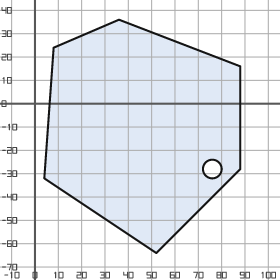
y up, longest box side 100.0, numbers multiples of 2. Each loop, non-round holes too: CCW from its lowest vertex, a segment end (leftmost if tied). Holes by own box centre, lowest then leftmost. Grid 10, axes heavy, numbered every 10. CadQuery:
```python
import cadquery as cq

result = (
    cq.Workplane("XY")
    .moveTo(52.0, -64.0)
    .lineTo(88.0, -28.0)
    .lineTo(88.0, 16.0)
    .lineTo(36.0, 36.0)
    .lineTo(8.0, 24.0)
    .lineTo(4.0, -32.0)
    .close()
    .moveTo(76.0, -28.0)
    .circle(4.0)
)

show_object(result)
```